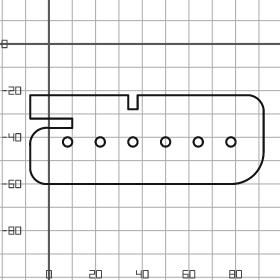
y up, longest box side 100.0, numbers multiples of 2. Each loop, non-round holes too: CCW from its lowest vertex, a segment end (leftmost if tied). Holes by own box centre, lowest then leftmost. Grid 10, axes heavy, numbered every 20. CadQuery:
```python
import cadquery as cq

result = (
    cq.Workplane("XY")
    .moveTo(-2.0, -60.0)
    .lineTo(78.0, -60.0)
    .threePointArc((88.0, -56.0), (92.0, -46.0))
    .lineTo(92.0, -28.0)
    .threePointArc((90.0, -24.0), (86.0, -22.0))
    .lineTo(38.0, -22.0)
    .lineTo(38.0, -28.0)
    .lineTo(34.0, -28.0)
    .lineTo(34.0, -22.0)
    .lineTo(-8.0, -22.0)
    .lineTo(-8.0, -32.0)
    .lineTo(10.0, -32.0)
    .lineTo(10.0, -36.0)
    .lineTo(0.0, -36.0)
    .threePointArc((-6.0, -38.0), (-8.0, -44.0))
    .lineTo(-8.0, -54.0)
    .threePointArc((-6.0, -58.0), (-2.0, -60.0))
    .close()
    .moveTo(8.0, -42.0)
    .circle(2.0)
    .moveTo(22.0, -42.0)
    .circle(2.0)
    .moveTo(36.0, -42.0)
    .circle(2.0)
    .moveTo(50.0, -42.0)
    .circle(2.0)
    .moveTo(64.0, -42.0)
    .circle(2.0)
    .moveTo(78.0, -42.0)
    .circle(2.0)
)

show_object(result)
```